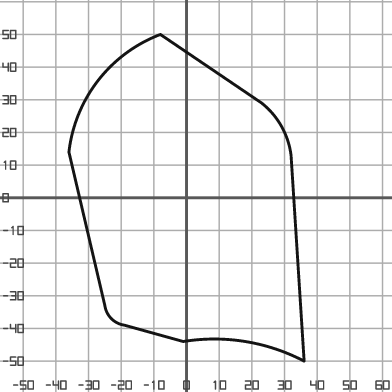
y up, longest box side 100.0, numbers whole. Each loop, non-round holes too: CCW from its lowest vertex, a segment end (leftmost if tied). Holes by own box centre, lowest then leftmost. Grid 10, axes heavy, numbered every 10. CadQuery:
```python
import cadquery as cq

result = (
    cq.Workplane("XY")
    .moveTo(36.0, -50.0)
    .lineTo(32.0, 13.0)
    .threePointArc((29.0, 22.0), (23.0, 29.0))
    .lineTo(-8.0, 50.0)
    .threePointArc((-27.0, 36.0), (-36.0, 14.0))
    .lineTo(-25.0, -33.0)
    .threePointArc((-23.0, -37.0), (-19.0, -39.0))
    .lineTo(-1.0, -44.0)
    .threePointArc((18.0, -44.0), (36.0, -50.0))
    .close()
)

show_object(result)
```